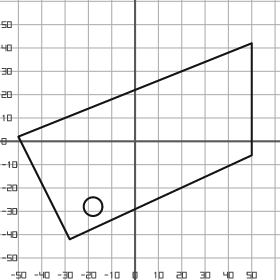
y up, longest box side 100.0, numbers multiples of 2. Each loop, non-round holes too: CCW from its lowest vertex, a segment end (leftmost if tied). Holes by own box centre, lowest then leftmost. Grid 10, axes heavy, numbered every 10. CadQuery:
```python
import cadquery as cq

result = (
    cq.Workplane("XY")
    .moveTo(-28.0, -42.0)
    .lineTo(50.0, -6.0)
    .lineTo(50.0, 42.0)
    .lineTo(-50.0, 2.0)
    .close()
    .moveTo(-18.0, -28.0)
    .circle(4.0)
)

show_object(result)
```